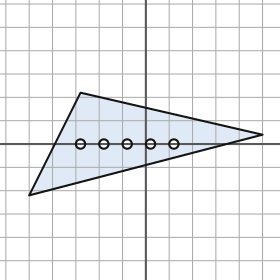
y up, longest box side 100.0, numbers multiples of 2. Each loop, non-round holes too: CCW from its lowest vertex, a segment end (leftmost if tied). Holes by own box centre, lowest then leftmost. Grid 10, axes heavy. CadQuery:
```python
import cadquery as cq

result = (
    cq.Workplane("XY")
    .moveTo(-50.0, -22.0)
    .lineTo(50.0, 4.0)
    .lineTo(-28.0, 22.0)
    .close()
    .moveTo(-28.0, 0.0)
    .circle(2.0)
    .moveTo(-18.0, 0.0)
    .circle(2.0)
    .moveTo(-8.0, 0.0)
    .circle(2.0)
    .moveTo(2.0, 0.0)
    .circle(2.0)
    .moveTo(12.0, 0.0)
    .circle(2.0)
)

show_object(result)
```